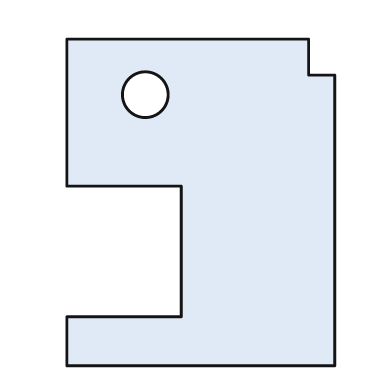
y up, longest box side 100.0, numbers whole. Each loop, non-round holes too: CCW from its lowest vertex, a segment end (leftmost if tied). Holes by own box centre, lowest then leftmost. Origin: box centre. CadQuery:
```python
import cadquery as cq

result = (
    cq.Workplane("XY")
    .moveTo(-41.0, -50.0)
    .lineTo(41.0, -50.0)
    .lineTo(41.0, 39.0)
    .lineTo(33.0, 39.0)
    .lineTo(33.0, 50.0)
    .lineTo(-41.0, 50.0)
    .lineTo(-41.0, 5.0)
    .lineTo(-6.0, 5.0)
    .lineTo(-6.0, -35.0)
    .lineTo(-41.0, -35.0)
    .close()
    .moveTo(-17.0, 33.0)
    .circle(7.0)
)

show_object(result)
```